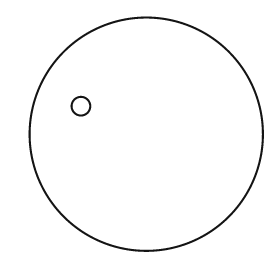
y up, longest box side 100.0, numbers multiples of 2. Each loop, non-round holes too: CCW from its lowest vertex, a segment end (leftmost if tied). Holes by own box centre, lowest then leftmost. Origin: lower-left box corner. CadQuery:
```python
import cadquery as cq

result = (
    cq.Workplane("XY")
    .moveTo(50.0, 50.0)
    .circle(50.0)
    .moveTo(22.0, 62.0)
    .circle(4.0)
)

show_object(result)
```